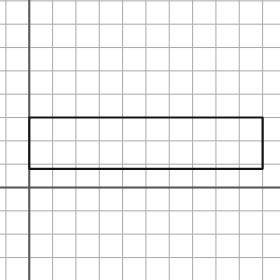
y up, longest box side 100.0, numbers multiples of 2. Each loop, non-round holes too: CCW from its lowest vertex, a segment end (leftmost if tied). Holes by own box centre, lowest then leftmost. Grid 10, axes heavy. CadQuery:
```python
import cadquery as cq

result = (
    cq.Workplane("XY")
    .moveTo(0.0, 8.0)
    .lineTo(100.0, 8.0)
    .lineTo(100.0, 30.0)
    .lineTo(0.0, 30.0)
    .close()
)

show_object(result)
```